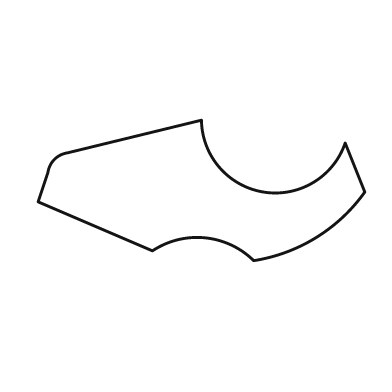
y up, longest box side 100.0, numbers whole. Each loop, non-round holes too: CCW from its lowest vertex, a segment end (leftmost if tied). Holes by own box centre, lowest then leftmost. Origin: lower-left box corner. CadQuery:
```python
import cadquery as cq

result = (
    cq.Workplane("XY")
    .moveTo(66.0, 0.0)
    .threePointArc((85.0, 7.0), (100.0, 21.0))
    .lineTo(94.0, 36.0)
    .threePointArc((69.0, 21.0), (50.0, 43.0))
    .lineTo(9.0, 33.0)
    .threePointArc((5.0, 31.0), (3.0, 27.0))
    .lineTo(0.0, 18.0)
    .lineTo(35.0, 3.0)
    .threePointArc((51.0, 7.0), (66.0, 0.0))
    .close()
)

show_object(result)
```